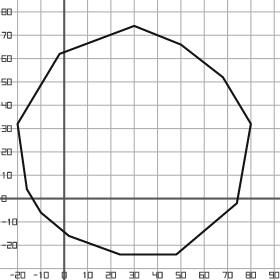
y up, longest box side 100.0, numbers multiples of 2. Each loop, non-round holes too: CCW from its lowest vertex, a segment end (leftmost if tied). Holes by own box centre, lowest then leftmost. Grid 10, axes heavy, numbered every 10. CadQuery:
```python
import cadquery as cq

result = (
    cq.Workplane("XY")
    .moveTo(24.0, -24.0)
    .lineTo(48.0, -24.0)
    .lineTo(74.0, -2.0)
    .lineTo(80.0, 32.0)
    .lineTo(68.0, 52.0)
    .lineTo(50.0, 66.0)
    .lineTo(30.0, 74.0)
    .lineTo(-2.0, 62.0)
    .lineTo(-20.0, 32.0)
    .lineTo(-16.0, 4.0)
    .lineTo(-10.0, -6.0)
    .lineTo(2.0, -16.0)
    .close()
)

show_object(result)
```